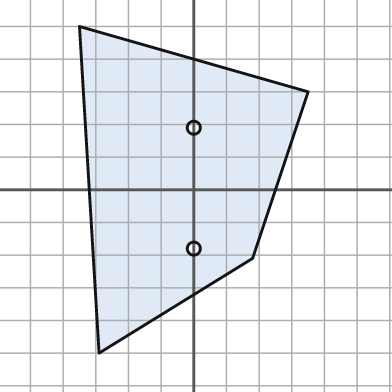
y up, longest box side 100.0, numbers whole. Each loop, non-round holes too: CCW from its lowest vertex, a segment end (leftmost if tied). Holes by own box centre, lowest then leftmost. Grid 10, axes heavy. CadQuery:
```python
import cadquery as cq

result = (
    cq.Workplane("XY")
    .moveTo(-29.0, -50.0)
    .lineTo(18.0, -21.0)
    .lineTo(35.0, 30.0)
    .lineTo(-35.0, 50.0)
    .close()
    .moveTo(0.0, -18.0)
    .circle(2.0)
    .moveTo(0.0, 19.0)
    .circle(2.0)
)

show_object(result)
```